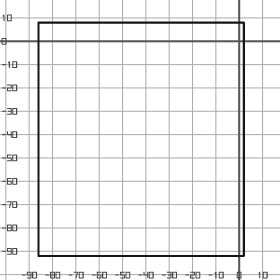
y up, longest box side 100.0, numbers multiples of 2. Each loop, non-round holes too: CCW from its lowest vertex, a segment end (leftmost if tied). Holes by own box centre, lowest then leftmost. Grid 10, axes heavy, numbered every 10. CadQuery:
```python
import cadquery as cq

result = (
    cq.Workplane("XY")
    .moveTo(-86.0, -92.0)
    .lineTo(2.0, -92.0)
    .lineTo(2.0, 8.0)
    .lineTo(-86.0, 8.0)
    .close()
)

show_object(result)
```